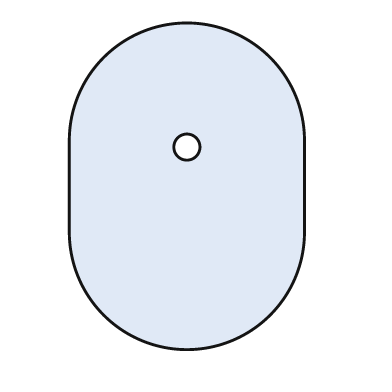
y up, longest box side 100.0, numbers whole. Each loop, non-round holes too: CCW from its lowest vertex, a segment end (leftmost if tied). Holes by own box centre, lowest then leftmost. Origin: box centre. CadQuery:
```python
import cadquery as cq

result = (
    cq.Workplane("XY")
    .moveTo(-36.0, -14.0)
    .threePointArc((0.0, -50.0), (36.0, -14.0))
    .lineTo(36.0, 14.0)
    .threePointArc((0.0, 50.0), (-36.0, 14.0))
    .close()
    .moveTo(0.0, 12.0)
    .circle(4.0)
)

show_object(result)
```